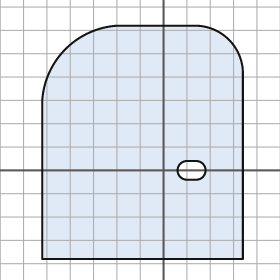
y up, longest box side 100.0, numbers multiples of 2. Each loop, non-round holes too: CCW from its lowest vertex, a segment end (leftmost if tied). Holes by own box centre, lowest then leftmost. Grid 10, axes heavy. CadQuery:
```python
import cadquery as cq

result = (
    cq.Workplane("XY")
    .moveTo(-52.0, -38.0)
    .lineTo(34.0, -38.0)
    .lineTo(34.0, 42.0)
    .threePointArc((28.0, 56.0), (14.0, 62.0))
    .lineTo(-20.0, 62.0)
    .threePointArc((-42.0, 52.0), (-52.0, 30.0))
    .close()
    .moveTo(10.0, -4.0)
    .lineTo(14.0, -4.0)
    .threePointArc((18.0, 0.0), (14.0, 4.0))
    .lineTo(10.0, 4.0)
    .threePointArc((6.0, 0.0), (10.0, -4.0))
    .close()
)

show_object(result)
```